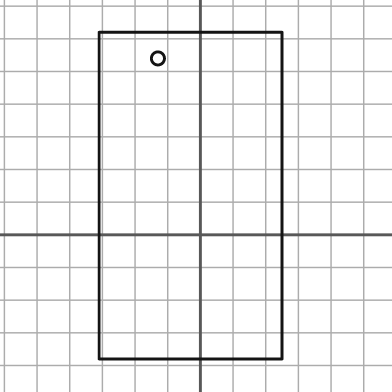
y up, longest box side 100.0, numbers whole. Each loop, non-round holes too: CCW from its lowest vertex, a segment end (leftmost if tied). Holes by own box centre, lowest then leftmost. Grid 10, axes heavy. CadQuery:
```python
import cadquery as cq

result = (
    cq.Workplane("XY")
    .moveTo(-31.0, -38.0)
    .lineTo(25.0, -38.0)
    .lineTo(25.0, 62.0)
    .lineTo(-31.0, 62.0)
    .close()
    .moveTo(-13.0, 54.0)
    .circle(2.0)
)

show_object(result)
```